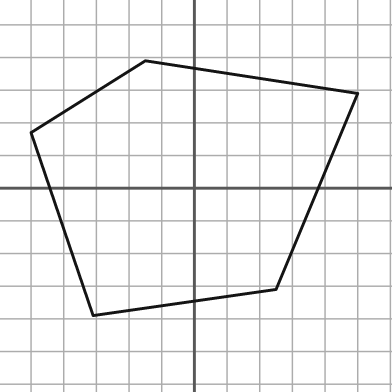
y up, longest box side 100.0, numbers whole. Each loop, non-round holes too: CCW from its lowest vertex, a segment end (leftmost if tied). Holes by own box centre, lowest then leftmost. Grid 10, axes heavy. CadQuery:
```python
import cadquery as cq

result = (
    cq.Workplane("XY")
    .moveTo(-31.0, -39.0)
    .lineTo(25.0, -31.0)
    .lineTo(50.0, 29.0)
    .lineTo(-15.0, 39.0)
    .lineTo(-50.0, 17.0)
    .close()
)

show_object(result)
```